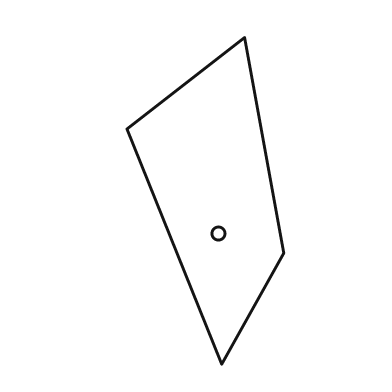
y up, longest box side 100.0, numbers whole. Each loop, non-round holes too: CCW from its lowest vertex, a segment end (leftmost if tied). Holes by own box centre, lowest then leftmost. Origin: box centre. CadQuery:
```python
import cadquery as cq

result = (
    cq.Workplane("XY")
    .moveTo(5.0, -50.0)
    .lineTo(24.0, -16.0)
    .lineTo(12.0, 50.0)
    .lineTo(-24.0, 22.0)
    .close()
    .moveTo(4.0, -10.0)
    .circle(2.0)
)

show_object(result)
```